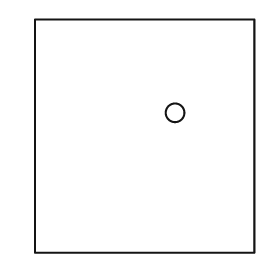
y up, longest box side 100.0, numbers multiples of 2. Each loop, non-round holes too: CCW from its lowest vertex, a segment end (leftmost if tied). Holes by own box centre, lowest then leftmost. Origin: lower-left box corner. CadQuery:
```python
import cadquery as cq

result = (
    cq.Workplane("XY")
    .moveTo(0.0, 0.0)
    .lineTo(94.0, 0.0)
    .lineTo(94.0, 100.0)
    .lineTo(0.0, 100.0)
    .close()
    .moveTo(60.0, 60.0)
    .circle(4.0)
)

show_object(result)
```